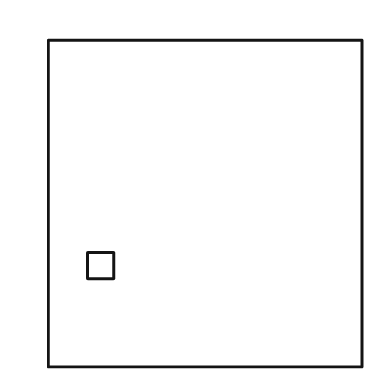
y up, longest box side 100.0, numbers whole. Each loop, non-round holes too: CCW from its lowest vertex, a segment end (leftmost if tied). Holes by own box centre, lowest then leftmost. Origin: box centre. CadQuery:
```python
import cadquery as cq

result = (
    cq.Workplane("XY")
    .moveTo(-48.0, -50.0)
    .lineTo(48.0, -50.0)
    .lineTo(48.0, 50.0)
    .lineTo(-48.0, 50.0)
    .close()
    .moveTo(-36.0, -23.0)
    .lineTo(-28.0, -23.0)
    .lineTo(-28.0, -15.0)
    .lineTo(-36.0, -15.0)
    .close()
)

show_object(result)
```